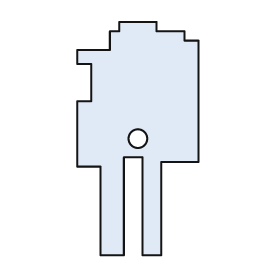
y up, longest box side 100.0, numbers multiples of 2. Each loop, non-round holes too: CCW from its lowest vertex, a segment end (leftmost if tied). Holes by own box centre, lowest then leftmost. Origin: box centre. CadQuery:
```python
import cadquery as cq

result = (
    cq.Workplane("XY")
    .moveTo(-16.0, -50.0)
    .lineTo(-6.0, -50.0)
    .lineTo(-6.0, -8.0)
    .lineTo(2.0, -8.0)
    .lineTo(2.0, -50.0)
    .lineTo(10.0, -50.0)
    .lineTo(10.0, -10.0)
    .lineTo(26.0, -10.0)
    .lineTo(26.0, 42.0)
    .lineTo(20.0, 42.0)
    .lineTo(20.0, 46.0)
    .lineTo(8.0, 46.0)
    .lineTo(8.0, 50.0)
    .lineTo(-8.0, 50.0)
    .lineTo(-8.0, 46.0)
    .lineTo(-12.0, 46.0)
    .lineTo(-12.0, 38.0)
    .lineTo(-26.0, 38.0)
    .lineTo(-26.0, 32.0)
    .lineTo(-20.0, 32.0)
    .lineTo(-20.0, 16.0)
    .lineTo(-26.0, 16.0)
    .lineTo(-26.0, -12.0)
    .lineTo(-16.0, -12.0)
    .close()
    .moveTo(0.0, 0.0)
    .circle(4.0)
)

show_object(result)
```